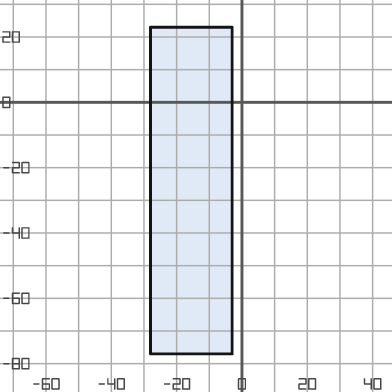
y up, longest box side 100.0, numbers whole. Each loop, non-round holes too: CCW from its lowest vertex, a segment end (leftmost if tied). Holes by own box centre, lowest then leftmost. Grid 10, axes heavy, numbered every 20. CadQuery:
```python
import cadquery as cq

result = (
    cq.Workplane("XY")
    .moveTo(-28.0, -77.0)
    .lineTo(-3.0, -77.0)
    .lineTo(-3.0, 23.0)
    .lineTo(-28.0, 23.0)
    .close()
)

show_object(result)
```